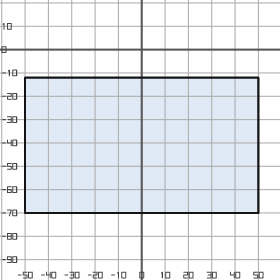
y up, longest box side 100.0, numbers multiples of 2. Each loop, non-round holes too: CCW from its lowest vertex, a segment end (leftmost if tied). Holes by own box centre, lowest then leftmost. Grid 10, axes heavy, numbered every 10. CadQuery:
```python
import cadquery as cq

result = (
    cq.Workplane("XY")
    .moveTo(-50.0, -70.0)
    .lineTo(50.0, -70.0)
    .lineTo(50.0, -12.0)
    .lineTo(-50.0, -12.0)
    .close()
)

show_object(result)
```